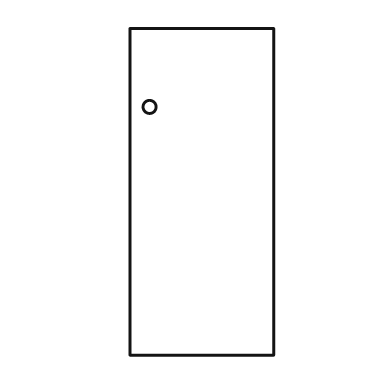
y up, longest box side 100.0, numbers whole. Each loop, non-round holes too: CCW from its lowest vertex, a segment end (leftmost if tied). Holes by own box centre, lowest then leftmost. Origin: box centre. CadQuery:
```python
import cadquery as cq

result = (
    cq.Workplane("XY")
    .moveTo(-22.0, -50.0)
    .lineTo(22.0, -50.0)
    .lineTo(22.0, 50.0)
    .lineTo(-22.0, 50.0)
    .close()
    .moveTo(-16.0, 26.0)
    .circle(2.0)
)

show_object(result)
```